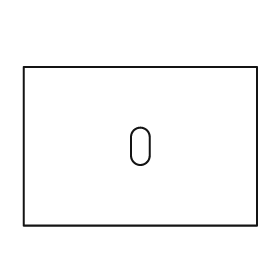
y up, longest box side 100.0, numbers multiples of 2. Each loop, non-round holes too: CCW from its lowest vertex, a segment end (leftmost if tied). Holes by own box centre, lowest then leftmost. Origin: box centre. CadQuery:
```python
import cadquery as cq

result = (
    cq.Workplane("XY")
    .moveTo(-50.0, -34.0)
    .lineTo(50.0, -34.0)
    .lineTo(50.0, 34.0)
    .lineTo(-50.0, 34.0)
    .close()
    .moveTo(-4.0, -4.0)
    .threePointArc((0.0, -8.0), (4.0, -4.0))
    .lineTo(4.0, 4.0)
    .threePointArc((0.0, 8.0), (-4.0, 4.0))
    .close()
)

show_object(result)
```